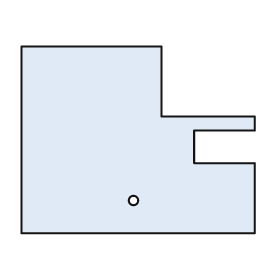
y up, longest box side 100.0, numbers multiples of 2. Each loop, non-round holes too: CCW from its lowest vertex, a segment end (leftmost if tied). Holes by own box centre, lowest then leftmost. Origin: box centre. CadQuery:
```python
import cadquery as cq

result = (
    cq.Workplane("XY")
    .moveTo(-50.0, -40.0)
    .lineTo(50.0, -40.0)
    .lineTo(50.0, -10.0)
    .lineTo(24.0, -10.0)
    .lineTo(24.0, 4.0)
    .lineTo(50.0, 4.0)
    .lineTo(50.0, 10.0)
    .lineTo(10.0, 10.0)
    .lineTo(10.0, 40.0)
    .lineTo(-50.0, 40.0)
    .close()
    .moveTo(-2.0, -26.0)
    .circle(2.0)
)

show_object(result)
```